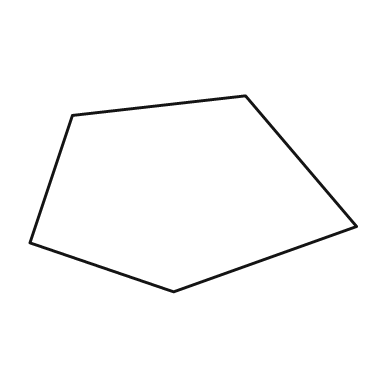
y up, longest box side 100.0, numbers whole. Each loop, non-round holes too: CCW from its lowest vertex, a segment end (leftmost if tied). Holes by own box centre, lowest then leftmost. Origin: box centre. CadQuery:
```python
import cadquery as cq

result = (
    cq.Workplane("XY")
    .moveTo(-6.0, -30.0)
    .lineTo(50.0, -10.0)
    .lineTo(16.0, 30.0)
    .lineTo(-37.0, 24.0)
    .lineTo(-50.0, -15.0)
    .close()
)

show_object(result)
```